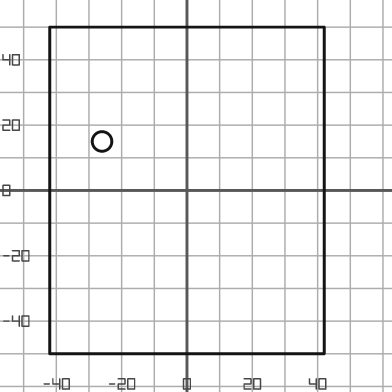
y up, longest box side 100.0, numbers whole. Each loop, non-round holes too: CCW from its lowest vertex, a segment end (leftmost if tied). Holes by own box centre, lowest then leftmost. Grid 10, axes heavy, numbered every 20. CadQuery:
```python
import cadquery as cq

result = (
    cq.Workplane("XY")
    .moveTo(-42.0, -50.0)
    .lineTo(42.0, -50.0)
    .lineTo(42.0, 50.0)
    .lineTo(-42.0, 50.0)
    .close()
    .moveTo(-26.0, 15.0)
    .circle(3.0)
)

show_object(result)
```